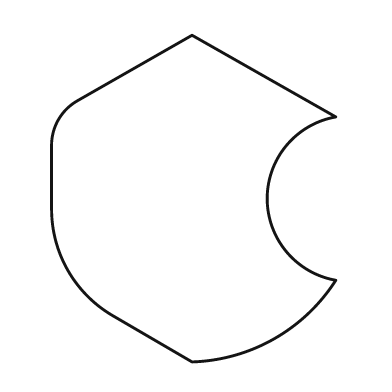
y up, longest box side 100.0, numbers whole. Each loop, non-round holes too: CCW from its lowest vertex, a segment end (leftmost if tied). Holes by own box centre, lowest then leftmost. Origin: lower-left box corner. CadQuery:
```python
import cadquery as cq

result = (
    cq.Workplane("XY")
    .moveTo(43.0, 0.0)
    .threePointArc((68.0, 7.0), (87.0, 25.0))
    .threePointArc((66.0, 50.0), (87.0, 75.0))
    .lineTo(43.0, 100.0)
    .lineTo(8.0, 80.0)
    .threePointArc((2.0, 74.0), (0.0, 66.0))
    .lineTo(0.0, 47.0)
    .threePointArc((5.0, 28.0), (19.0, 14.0))
    .close()
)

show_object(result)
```